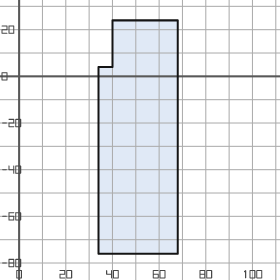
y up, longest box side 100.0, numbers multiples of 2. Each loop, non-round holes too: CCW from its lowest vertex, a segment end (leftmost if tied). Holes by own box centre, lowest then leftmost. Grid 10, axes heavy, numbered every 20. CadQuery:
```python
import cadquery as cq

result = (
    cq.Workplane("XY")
    .moveTo(34.0, -76.0)
    .lineTo(68.0, -76.0)
    .lineTo(68.0, 24.0)
    .lineTo(40.0, 24.0)
    .lineTo(40.0, 4.0)
    .lineTo(34.0, 4.0)
    .close()
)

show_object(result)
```